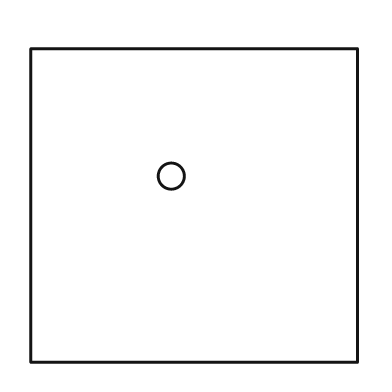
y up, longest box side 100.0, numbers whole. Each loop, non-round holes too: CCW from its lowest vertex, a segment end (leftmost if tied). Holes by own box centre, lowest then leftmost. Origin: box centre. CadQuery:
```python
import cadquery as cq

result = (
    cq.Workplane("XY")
    .moveTo(-50.0, -48.0)
    .lineTo(50.0, -48.0)
    .lineTo(50.0, 48.0)
    .lineTo(-50.0, 48.0)
    .close()
    .moveTo(-7.0, 9.0)
    .circle(4.0)
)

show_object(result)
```